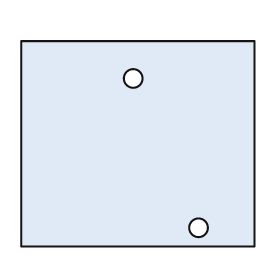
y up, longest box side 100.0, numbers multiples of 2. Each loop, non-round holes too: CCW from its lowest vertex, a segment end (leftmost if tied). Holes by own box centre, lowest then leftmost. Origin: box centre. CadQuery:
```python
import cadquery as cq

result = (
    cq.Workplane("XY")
    .moveTo(-50.0, -44.0)
    .lineTo(50.0, -44.0)
    .lineTo(50.0, 44.0)
    .lineTo(-50.0, 44.0)
    .close()
    .moveTo(26.0, -36.0)
    .circle(4.0)
    .moveTo(-2.0, 28.0)
    .circle(4.0)
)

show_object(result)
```